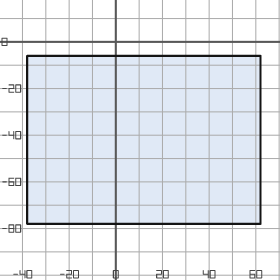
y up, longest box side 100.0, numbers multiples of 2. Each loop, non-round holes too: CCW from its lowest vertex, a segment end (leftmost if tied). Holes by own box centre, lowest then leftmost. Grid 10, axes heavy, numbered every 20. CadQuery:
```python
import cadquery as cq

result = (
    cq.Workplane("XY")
    .moveTo(-38.0, -78.0)
    .lineTo(62.0, -78.0)
    .lineTo(62.0, -6.0)
    .lineTo(-38.0, -6.0)
    .close()
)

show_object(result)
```